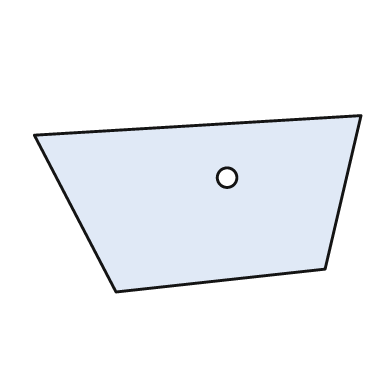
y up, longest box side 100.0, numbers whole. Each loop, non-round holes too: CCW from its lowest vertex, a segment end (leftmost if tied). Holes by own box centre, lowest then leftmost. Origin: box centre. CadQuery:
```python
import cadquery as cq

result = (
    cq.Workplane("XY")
    .moveTo(-25.0, -27.0)
    .lineTo(39.0, -20.0)
    .lineTo(50.0, 27.0)
    .lineTo(-50.0, 21.0)
    .close()
    .moveTo(9.0, 8.0)
    .circle(3.0)
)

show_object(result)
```